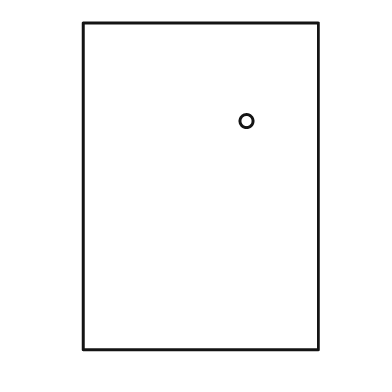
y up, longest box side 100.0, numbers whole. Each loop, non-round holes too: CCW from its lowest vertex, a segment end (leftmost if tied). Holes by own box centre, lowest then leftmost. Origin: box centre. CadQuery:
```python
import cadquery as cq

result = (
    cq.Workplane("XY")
    .moveTo(-36.0, -50.0)
    .lineTo(36.0, -50.0)
    .lineTo(36.0, 50.0)
    .lineTo(-36.0, 50.0)
    .close()
    .moveTo(14.0, 20.0)
    .circle(2.0)
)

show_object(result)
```